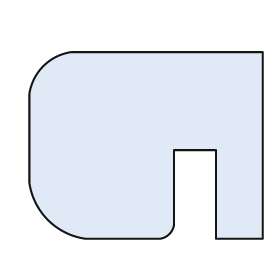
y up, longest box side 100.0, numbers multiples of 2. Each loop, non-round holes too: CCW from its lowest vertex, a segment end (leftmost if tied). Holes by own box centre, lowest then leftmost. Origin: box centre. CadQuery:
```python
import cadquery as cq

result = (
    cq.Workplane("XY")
    .moveTo(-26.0, -40.0)
    .lineTo(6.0, -40.0)
    .threePointArc((10.0, -38.0), (12.0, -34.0))
    .lineTo(12.0, -2.0)
    .lineTo(30.0, -2.0)
    .lineTo(30.0, -40.0)
    .lineTo(50.0, -40.0)
    .lineTo(50.0, 40.0)
    .lineTo(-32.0, 40.0)
    .threePointArc((-44.0, 34.0), (-50.0, 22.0))
    .lineTo(-50.0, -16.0)
    .threePointArc((-42.0, -32.0), (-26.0, -40.0))
    .close()
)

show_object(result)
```